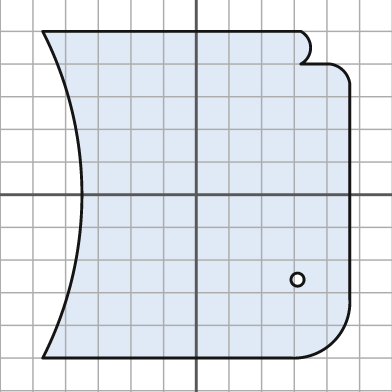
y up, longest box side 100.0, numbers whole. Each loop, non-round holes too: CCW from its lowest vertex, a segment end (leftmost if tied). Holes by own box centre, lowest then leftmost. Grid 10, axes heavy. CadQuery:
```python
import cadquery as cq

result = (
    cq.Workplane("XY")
    .moveTo(-47.0, -50.0)
    .lineTo(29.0, -50.0)
    .threePointArc((42.0, -45.0), (47.0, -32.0))
    .lineTo(47.0, 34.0)
    .threePointArc((45.0, 38.0), (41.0, 40.0))
    .lineTo(32.0, 40.0)
    .threePointArc((35.0, 45.0), (32.0, 50.0))
    .lineTo(-47.0, 50.0)
    .threePointArc((-35.0, 0.0), (-47.0, -50.0))
    .close()
    .moveTo(31.0, -26.0)
    .circle(2.0)
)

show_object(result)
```